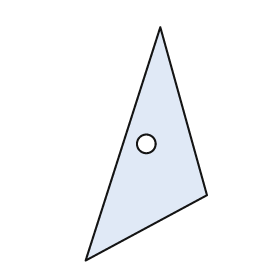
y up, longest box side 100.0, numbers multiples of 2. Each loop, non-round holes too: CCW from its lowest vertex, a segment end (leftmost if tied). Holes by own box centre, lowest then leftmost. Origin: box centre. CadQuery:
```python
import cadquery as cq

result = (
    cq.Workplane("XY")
    .moveTo(-26.0, -50.0)
    .lineTo(26.0, -22.0)
    .lineTo(6.0, 50.0)
    .close()
    .moveTo(0.0, 0.0)
    .circle(4.0)
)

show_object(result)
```